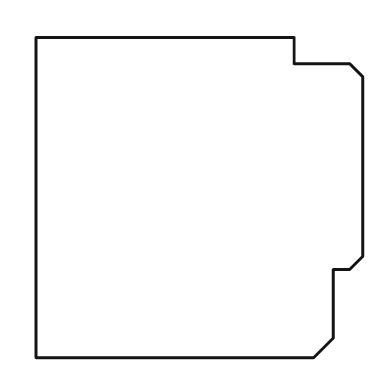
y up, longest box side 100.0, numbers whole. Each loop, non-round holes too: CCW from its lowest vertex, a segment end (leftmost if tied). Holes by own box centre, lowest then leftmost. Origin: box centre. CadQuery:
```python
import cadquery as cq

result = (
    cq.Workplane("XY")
    .moveTo(-50.0, -49.0)
    .lineTo(35.0, -49.0)
    .lineTo(41.0, -43.0)
    .lineTo(41.0, -22.0)
    .lineTo(46.0, -22.0)
    .lineTo(50.0, -18.0)
    .lineTo(50.0, 37.0)
    .lineTo(46.0, 41.0)
    .lineTo(29.0, 41.0)
    .lineTo(29.0, 49.0)
    .lineTo(-50.0, 49.0)
    .close()
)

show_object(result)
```